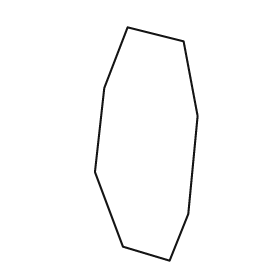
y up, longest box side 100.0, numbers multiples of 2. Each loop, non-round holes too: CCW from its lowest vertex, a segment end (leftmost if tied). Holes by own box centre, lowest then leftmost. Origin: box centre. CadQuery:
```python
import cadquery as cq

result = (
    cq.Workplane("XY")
    .moveTo(10.0, -50.0)
    .lineTo(18.0, -30.0)
    .lineTo(22.0, 12.0)
    .lineTo(16.0, 44.0)
    .lineTo(-8.0, 50.0)
    .lineTo(-18.0, 24.0)
    .lineTo(-22.0, -12.0)
    .lineTo(-10.0, -44.0)
    .close()
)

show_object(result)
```